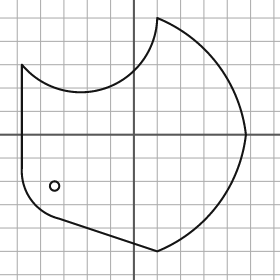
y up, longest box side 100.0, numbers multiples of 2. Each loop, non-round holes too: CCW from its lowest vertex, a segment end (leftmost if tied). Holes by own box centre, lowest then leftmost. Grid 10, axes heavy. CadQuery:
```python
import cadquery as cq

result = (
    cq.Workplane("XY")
    .moveTo(10.0, -50.0)
    .threePointArc((36.0, -30.0), (48.0, 0.0))
    .threePointArc((36.0, 30.0), (10.0, 50.0))
    .threePointArc((-12.0, 20.0), (-48.0, 30.0))
    .lineTo(-48.0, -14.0)
    .threePointArc((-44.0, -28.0), (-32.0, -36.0))
    .close()
    .moveTo(-34.0, -22.0)
    .circle(2.0)
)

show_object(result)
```